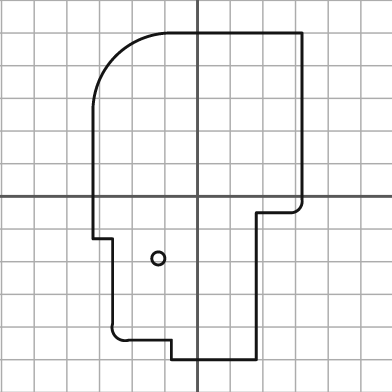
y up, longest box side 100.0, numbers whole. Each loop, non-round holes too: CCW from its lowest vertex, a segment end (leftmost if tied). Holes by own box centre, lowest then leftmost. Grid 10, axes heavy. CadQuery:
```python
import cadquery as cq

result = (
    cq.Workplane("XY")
    .moveTo(-8.0, -50.0)
    .lineTo(18.0, -50.0)
    .lineTo(18.0, -5.0)
    .lineTo(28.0, -5.0)
    .threePointArc((31.0, -4.0), (32.0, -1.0))
    .lineTo(32.0, 50.0)
    .lineTo(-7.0, 50.0)
    .threePointArc((-25.0, 43.0), (-32.0, 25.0))
    .lineTo(-32.0, -13.0)
    .lineTo(-26.0, -13.0)
    .lineTo(-26.0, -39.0)
    .threePointArc((-25.0, -43.0), (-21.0, -44.0))
    .lineTo(-8.0, -44.0)
    .close()
    .moveTo(-12.0, -19.0)
    .circle(2.0)
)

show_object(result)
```